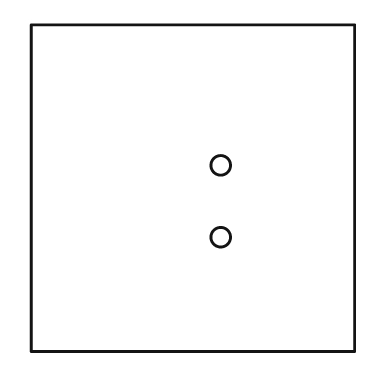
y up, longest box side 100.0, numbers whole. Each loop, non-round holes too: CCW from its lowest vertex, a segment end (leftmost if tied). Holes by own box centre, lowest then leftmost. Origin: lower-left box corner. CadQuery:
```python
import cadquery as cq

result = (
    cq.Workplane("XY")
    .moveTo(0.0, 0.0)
    .lineTo(99.0, 0.0)
    .lineTo(99.0, 100.0)
    .lineTo(0.0, 100.0)
    .close()
    .moveTo(58.0, 35.0)
    .circle(3.0)
    .moveTo(58.0, 57.0)
    .circle(3.0)
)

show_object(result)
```